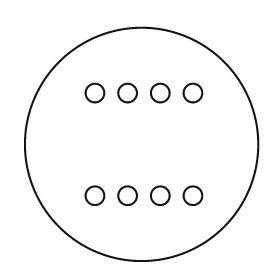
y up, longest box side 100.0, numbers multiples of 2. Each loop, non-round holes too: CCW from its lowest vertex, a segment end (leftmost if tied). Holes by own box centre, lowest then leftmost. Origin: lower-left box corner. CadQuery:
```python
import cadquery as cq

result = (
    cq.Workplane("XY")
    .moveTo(50.0, 50.0)
    .circle(50.0)
    .moveTo(30.0, 28.0)
    .circle(4.0)
    .moveTo(44.0, 28.0)
    .circle(4.0)
    .moveTo(58.0, 28.0)
    .circle(4.0)
    .moveTo(72.0, 28.0)
    .circle(4.0)
    .moveTo(30.0, 72.0)
    .circle(4.0)
    .moveTo(44.0, 72.0)
    .circle(4.0)
    .moveTo(58.0, 72.0)
    .circle(4.0)
    .moveTo(72.0, 72.0)
    .circle(4.0)
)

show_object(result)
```